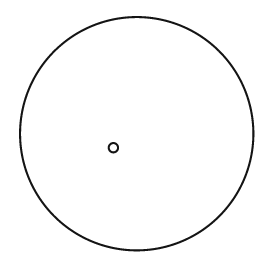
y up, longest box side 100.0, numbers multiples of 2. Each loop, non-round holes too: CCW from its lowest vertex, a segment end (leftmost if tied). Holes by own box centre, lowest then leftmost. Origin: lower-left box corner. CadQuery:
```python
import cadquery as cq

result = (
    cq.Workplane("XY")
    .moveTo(50.0, 50.0)
    .circle(50.0)
    .moveTo(40.0, 44.0)
    .circle(2.0)
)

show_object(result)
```